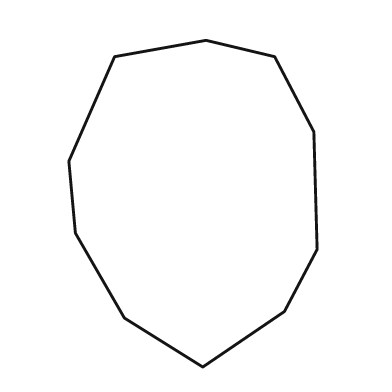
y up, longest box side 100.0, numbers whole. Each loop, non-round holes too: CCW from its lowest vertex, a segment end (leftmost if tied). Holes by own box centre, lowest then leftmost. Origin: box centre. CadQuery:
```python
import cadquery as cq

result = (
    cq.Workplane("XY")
    .moveTo(3.0, -50.0)
    .lineTo(28.0, -33.0)
    .lineTo(38.0, -14.0)
    .lineTo(37.0, 22.0)
    .lineTo(25.0, 45.0)
    .lineTo(4.0, 50.0)
    .lineTo(-24.0, 45.0)
    .lineTo(-38.0, 13.0)
    .lineTo(-36.0, -9.0)
    .lineTo(-21.0, -35.0)
    .close()
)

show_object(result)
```